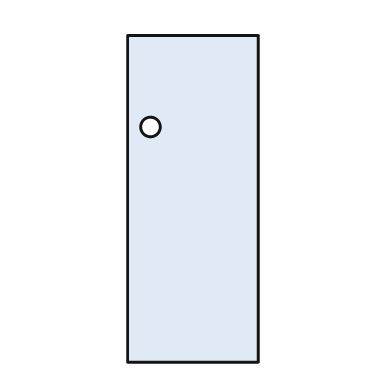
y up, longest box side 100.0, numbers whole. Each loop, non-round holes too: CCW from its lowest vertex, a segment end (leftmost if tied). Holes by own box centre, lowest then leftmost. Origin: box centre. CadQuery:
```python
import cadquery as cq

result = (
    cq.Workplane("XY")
    .moveTo(-20.0, -50.0)
    .lineTo(20.0, -50.0)
    .lineTo(20.0, 50.0)
    .lineTo(-20.0, 50.0)
    .close()
    .moveTo(-13.0, 22.0)
    .circle(3.0)
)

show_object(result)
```